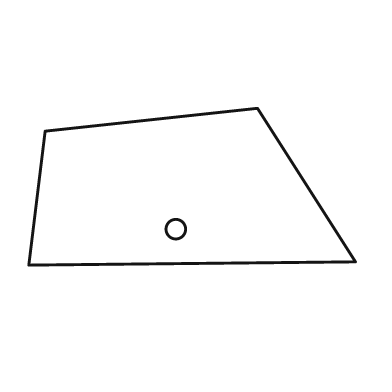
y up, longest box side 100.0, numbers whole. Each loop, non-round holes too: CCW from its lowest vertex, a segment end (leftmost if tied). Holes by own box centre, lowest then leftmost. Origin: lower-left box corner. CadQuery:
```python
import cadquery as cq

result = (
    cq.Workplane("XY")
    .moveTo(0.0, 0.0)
    .lineTo(100.0, 1.0)
    .lineTo(70.0, 48.0)
    .lineTo(5.0, 41.0)
    .close()
    .moveTo(45.0, 11.0)
    .circle(3.0)
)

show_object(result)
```